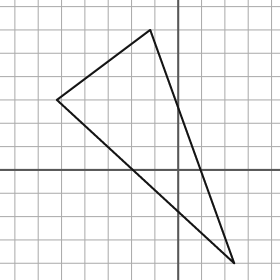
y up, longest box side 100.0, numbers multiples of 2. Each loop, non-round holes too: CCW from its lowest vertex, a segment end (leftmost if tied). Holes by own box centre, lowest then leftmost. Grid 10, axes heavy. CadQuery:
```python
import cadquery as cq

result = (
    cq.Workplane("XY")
    .moveTo(24.0, -40.0)
    .lineTo(-12.0, 60.0)
    .lineTo(-52.0, 30.0)
    .close()
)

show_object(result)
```